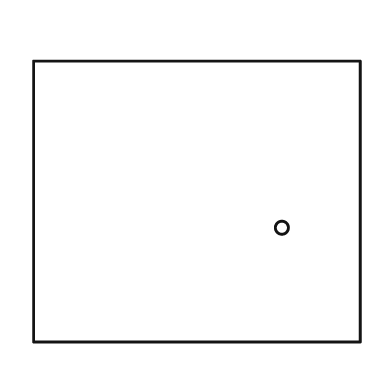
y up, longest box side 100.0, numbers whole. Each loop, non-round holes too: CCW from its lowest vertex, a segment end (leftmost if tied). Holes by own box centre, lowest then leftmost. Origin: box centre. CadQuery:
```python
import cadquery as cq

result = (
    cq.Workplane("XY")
    .moveTo(-50.0, -43.0)
    .lineTo(50.0, -43.0)
    .lineTo(50.0, 43.0)
    .lineTo(-50.0, 43.0)
    .close()
    .moveTo(26.0, -8.0)
    .circle(2.0)
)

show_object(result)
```